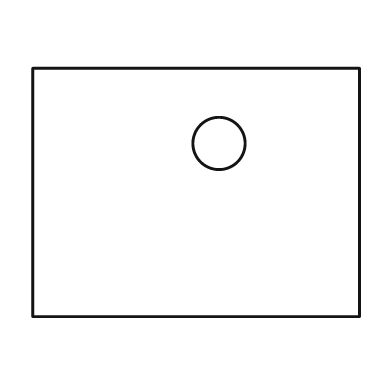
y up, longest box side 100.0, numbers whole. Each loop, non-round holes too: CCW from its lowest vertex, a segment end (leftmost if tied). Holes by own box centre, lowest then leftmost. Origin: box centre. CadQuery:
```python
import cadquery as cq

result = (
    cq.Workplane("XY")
    .moveTo(-50.0, -38.0)
    .lineTo(50.0, -38.0)
    .lineTo(50.0, 38.0)
    .lineTo(-50.0, 38.0)
    .close()
    .moveTo(7.0, 15.0)
    .circle(8.0)
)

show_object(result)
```